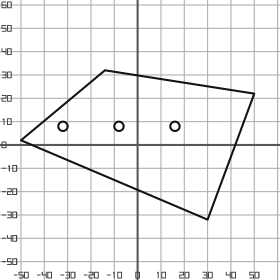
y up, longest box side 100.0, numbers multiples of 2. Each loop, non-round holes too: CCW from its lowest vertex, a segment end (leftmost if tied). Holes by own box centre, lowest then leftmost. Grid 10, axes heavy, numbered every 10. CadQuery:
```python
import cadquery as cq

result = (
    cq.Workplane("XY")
    .moveTo(30.0, -32.0)
    .lineTo(50.0, 22.0)
    .lineTo(-14.0, 32.0)
    .lineTo(-50.0, 2.0)
    .close()
    .moveTo(-32.0, 8.0)
    .circle(2.0)
    .moveTo(-8.0, 8.0)
    .circle(2.0)
    .moveTo(16.0, 8.0)
    .circle(2.0)
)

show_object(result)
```